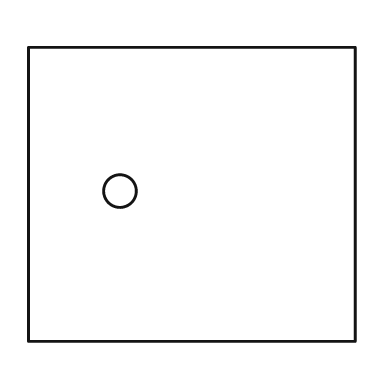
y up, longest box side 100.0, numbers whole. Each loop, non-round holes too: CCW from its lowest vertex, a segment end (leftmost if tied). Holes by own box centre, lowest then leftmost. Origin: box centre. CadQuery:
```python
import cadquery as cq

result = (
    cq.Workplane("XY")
    .moveTo(-50.0, -45.0)
    .lineTo(50.0, -45.0)
    .lineTo(50.0, 45.0)
    .lineTo(-50.0, 45.0)
    .close()
    .moveTo(-22.0, 1.0)
    .circle(5.0)
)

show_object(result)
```